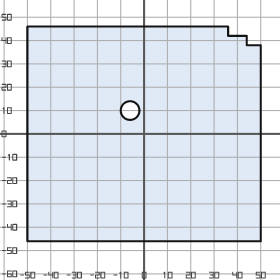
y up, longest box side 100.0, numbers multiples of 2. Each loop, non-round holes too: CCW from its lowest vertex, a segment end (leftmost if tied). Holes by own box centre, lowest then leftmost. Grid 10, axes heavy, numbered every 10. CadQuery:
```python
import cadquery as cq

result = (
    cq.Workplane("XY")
    .moveTo(-50.0, -46.0)
    .lineTo(50.0, -46.0)
    .lineTo(50.0, 38.0)
    .lineTo(44.0, 38.0)
    .lineTo(44.0, 42.0)
    .lineTo(36.0, 42.0)
    .lineTo(36.0, 46.0)
    .lineTo(-50.0, 46.0)
    .close()
    .moveTo(-6.0, 10.0)
    .circle(4.0)
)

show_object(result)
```